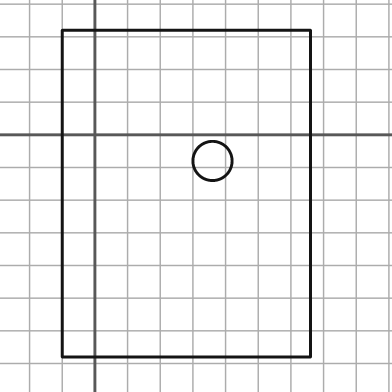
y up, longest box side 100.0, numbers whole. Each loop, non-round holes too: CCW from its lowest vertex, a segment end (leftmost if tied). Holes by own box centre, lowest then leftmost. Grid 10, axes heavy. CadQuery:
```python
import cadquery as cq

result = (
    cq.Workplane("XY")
    .moveTo(-10.0, -68.0)
    .lineTo(66.0, -68.0)
    .lineTo(66.0, 32.0)
    .lineTo(-10.0, 32.0)
    .close()
    .moveTo(36.0, -8.0)
    .circle(6.0)
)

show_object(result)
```